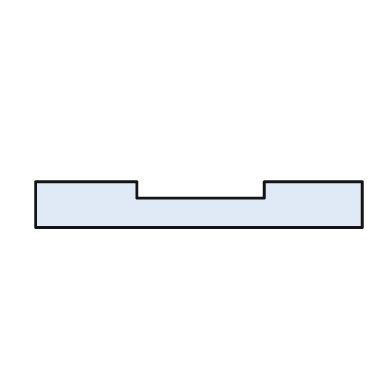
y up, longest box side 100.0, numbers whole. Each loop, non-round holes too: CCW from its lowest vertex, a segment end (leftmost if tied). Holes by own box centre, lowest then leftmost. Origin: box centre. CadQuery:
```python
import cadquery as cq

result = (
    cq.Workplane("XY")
    .moveTo(-50.0, -7.0)
    .lineTo(50.0, -7.0)
    .lineTo(50.0, 7.0)
    .lineTo(20.0, 7.0)
    .lineTo(20.0, 2.0)
    .lineTo(-19.0, 2.0)
    .lineTo(-19.0, 7.0)
    .lineTo(-50.0, 7.0)
    .close()
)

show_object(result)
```